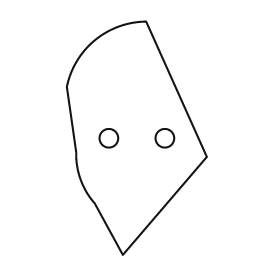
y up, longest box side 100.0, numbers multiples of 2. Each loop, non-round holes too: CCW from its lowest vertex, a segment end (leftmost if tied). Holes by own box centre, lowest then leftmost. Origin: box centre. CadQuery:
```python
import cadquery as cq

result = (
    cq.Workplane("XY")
    .moveTo(-6.0, -50.0)
    .lineTo(30.0, -8.0)
    .lineTo(4.0, 50.0)
    .threePointArc((-18.0, 42.0), (-30.0, 22.0))
    .lineTo(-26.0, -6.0)
    .threePointArc((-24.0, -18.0), (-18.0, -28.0))
    .close()
    .moveTo(-12.0, 0.0)
    .circle(4.0)
    .moveTo(12.0, 0.0)
    .circle(4.0)
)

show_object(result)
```